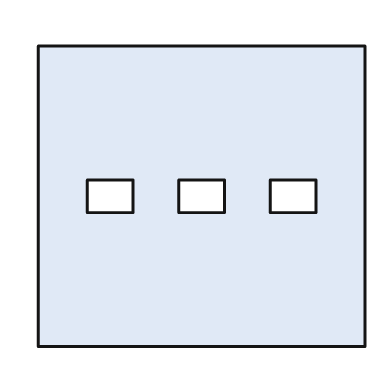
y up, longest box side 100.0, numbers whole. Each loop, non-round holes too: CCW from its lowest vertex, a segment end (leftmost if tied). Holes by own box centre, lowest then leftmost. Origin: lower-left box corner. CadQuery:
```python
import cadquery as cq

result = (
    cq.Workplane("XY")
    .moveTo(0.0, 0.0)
    .lineTo(100.0, 0.0)
    .lineTo(100.0, 92.0)
    .lineTo(0.0, 92.0)
    .close()
    .moveTo(15.0, 41.0)
    .lineTo(29.0, 41.0)
    .lineTo(29.0, 51.0)
    .lineTo(15.0, 51.0)
    .close()
    .moveTo(43.0, 41.0)
    .lineTo(57.0, 41.0)
    .lineTo(57.0, 51.0)
    .lineTo(43.0, 51.0)
    .close()
    .moveTo(71.0, 41.0)
    .lineTo(85.0, 41.0)
    .lineTo(85.0, 51.0)
    .lineTo(71.0, 51.0)
    .close()
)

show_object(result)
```